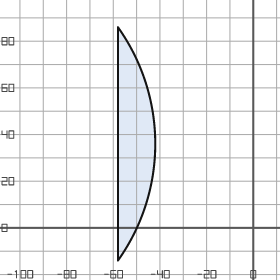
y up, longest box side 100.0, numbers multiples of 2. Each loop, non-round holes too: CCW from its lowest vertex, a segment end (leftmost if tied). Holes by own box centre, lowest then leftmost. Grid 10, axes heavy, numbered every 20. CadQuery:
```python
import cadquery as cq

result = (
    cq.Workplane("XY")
    .moveTo(-58.0, -14.0)
    .threePointArc((-42.0, 36.0), (-58.0, 86.0))
    .close()
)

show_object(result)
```